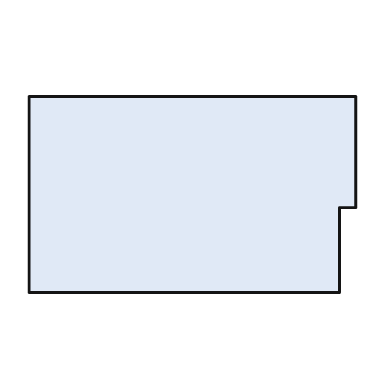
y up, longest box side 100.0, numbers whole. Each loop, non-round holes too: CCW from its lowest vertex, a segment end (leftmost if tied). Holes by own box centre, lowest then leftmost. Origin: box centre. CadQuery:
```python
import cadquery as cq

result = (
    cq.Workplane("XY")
    .moveTo(-50.0, -30.0)
    .lineTo(45.0, -30.0)
    .lineTo(45.0, -4.0)
    .lineTo(50.0, -4.0)
    .lineTo(50.0, 30.0)
    .lineTo(-50.0, 30.0)
    .close()
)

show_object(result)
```